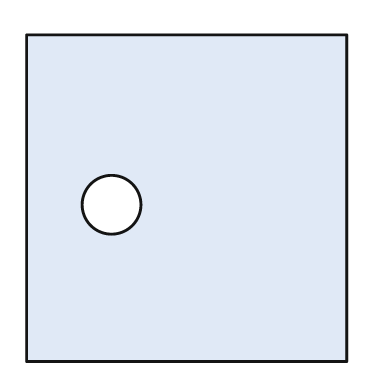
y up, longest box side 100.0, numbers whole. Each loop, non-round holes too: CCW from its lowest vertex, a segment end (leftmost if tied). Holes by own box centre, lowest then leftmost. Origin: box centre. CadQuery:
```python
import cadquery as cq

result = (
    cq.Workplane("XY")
    .moveTo(-49.0, -50.0)
    .lineTo(49.0, -50.0)
    .lineTo(49.0, 50.0)
    .lineTo(-49.0, 50.0)
    .close()
    .moveTo(-23.0, -2.0)
    .circle(9.0)
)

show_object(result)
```